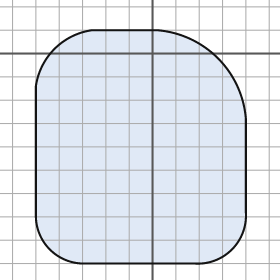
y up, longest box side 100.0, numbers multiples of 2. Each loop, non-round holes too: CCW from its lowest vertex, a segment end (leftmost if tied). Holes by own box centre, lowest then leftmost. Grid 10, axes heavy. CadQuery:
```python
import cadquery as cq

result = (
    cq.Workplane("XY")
    .moveTo(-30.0, -90.0)
    .lineTo(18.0, -90.0)
    .threePointArc((34.0, -84.0), (40.0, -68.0))
    .lineTo(40.0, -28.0)
    .threePointArc((28.0, -2.0), (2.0, 10.0))
    .lineTo(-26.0, 10.0)
    .threePointArc((-42.0, 2.0), (-50.0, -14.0))
    .lineTo(-50.0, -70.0)
    .threePointArc((-44.0, -84.0), (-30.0, -90.0))
    .close()
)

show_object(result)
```